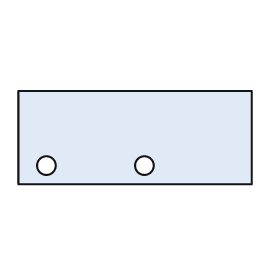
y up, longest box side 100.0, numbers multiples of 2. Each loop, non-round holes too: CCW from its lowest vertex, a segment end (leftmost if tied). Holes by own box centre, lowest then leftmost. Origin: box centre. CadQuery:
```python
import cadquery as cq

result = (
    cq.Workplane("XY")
    .moveTo(-50.0, -20.0)
    .lineTo(50.0, -20.0)
    .lineTo(50.0, 20.0)
    .lineTo(-50.0, 20.0)
    .close()
    .moveTo(-38.0, -12.0)
    .circle(4.0)
    .moveTo(4.0, -12.0)
    .circle(4.0)
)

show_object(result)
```